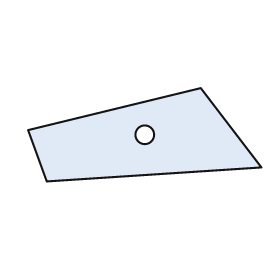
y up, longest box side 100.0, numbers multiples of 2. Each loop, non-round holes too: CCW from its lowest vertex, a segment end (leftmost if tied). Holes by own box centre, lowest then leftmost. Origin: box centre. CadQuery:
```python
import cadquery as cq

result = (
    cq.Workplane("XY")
    .moveTo(-42.0, -20.0)
    .lineTo(50.0, -14.0)
    .lineTo(24.0, 20.0)
    .lineTo(-50.0, 2.0)
    .close()
    .moveTo(0.0, 0.0)
    .circle(4.0)
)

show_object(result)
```